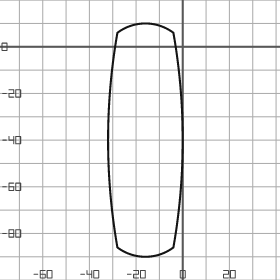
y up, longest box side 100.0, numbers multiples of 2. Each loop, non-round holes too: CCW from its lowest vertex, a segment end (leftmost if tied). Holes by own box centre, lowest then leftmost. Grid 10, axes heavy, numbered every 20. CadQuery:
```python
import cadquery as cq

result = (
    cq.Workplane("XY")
    .moveTo(-28.0, -86.0)
    .threePointArc((-16.0, -90.0), (-4.0, -86.0))
    .threePointArc((0.0, -40.0), (-4.0, 6.0))
    .threePointArc((-16.0, 10.0), (-28.0, 6.0))
    .threePointArc((-32.0, -40.0), (-28.0, -86.0))
    .close()
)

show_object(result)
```